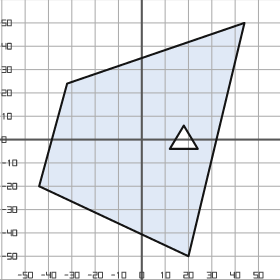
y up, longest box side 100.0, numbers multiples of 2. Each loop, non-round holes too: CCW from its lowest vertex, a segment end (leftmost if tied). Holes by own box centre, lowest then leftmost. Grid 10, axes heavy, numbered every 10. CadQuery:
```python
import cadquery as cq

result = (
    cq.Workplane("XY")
    .moveTo(20.0, -50.0)
    .lineTo(44.0, 50.0)
    .lineTo(-32.0, 24.0)
    .lineTo(-44.0, -20.0)
    .close()
    .moveTo(12.0, -4.0)
    .lineTo(24.0, -4.0)
    .lineTo(18.0, 6.0)
    .close()
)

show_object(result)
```